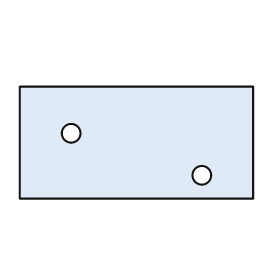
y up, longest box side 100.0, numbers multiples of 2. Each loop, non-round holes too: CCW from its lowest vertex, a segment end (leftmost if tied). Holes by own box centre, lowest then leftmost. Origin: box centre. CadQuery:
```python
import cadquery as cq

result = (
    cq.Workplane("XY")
    .moveTo(-50.0, -24.0)
    .lineTo(50.0, -24.0)
    .lineTo(50.0, 24.0)
    .lineTo(-50.0, 24.0)
    .close()
    .moveTo(28.0, -14.0)
    .circle(4.0)
    .moveTo(-28.0, 4.0)
    .circle(4.0)
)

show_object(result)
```